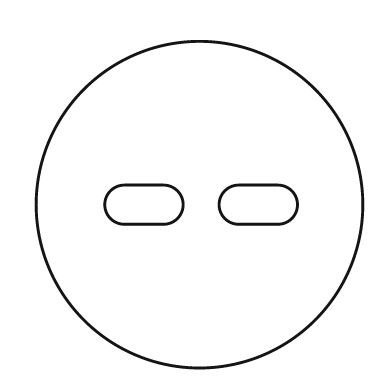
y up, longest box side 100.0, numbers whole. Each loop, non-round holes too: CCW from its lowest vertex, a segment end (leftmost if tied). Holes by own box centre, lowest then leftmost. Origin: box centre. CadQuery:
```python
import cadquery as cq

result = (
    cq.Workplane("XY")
    .moveTo(0.0, 0.0)
    .circle(50.0)
    .moveTo(-23.0, -6.0)
    .lineTo(-11.0, -6.0)
    .threePointArc((-5.0, 0.0), (-11.0, 6.0))
    .lineTo(-23.0, 6.0)
    .threePointArc((-29.0, 0.0), (-23.0, -6.0))
    .close()
    .moveTo(12.0, -6.0)
    .lineTo(24.0, -6.0)
    .threePointArc((30.0, 0.0), (24.0, 6.0))
    .lineTo(12.0, 6.0)
    .threePointArc((6.0, 0.0), (12.0, -6.0))
    .close()
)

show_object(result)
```